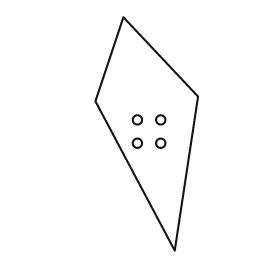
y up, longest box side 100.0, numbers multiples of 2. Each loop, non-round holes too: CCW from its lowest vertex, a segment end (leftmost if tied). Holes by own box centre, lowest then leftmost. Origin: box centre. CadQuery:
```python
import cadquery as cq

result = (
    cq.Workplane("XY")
    .moveTo(12.0, -50.0)
    .lineTo(22.0, 16.0)
    .lineTo(-10.0, 50.0)
    .lineTo(-22.0, 14.0)
    .close()
    .moveTo(-4.0, -4.0)
    .circle(2.0)
    .moveTo(6.0, -4.0)
    .circle(2.0)
    .moveTo(-4.0, 6.0)
    .circle(2.0)
    .moveTo(6.0, 6.0)
    .circle(2.0)
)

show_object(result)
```